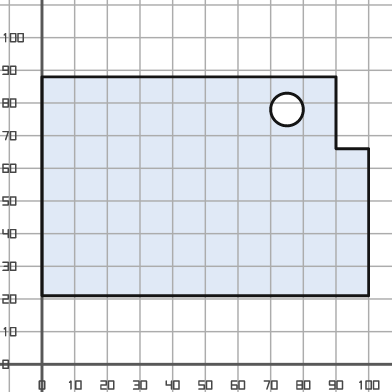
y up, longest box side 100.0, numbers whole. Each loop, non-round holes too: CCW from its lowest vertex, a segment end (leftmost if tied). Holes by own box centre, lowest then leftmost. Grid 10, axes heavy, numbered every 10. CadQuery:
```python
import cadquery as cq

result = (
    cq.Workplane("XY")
    .moveTo(0.0, 21.0)
    .lineTo(100.0, 21.0)
    .lineTo(100.0, 66.0)
    .lineTo(90.0, 66.0)
    .lineTo(90.0, 88.0)
    .lineTo(0.0, 88.0)
    .close()
    .moveTo(75.0, 78.0)
    .circle(5.0)
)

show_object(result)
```